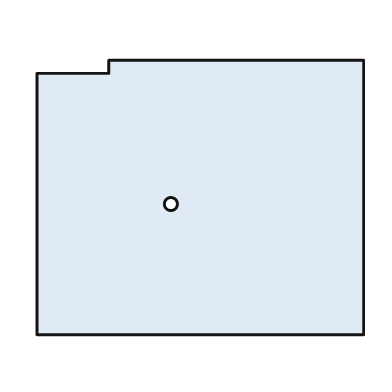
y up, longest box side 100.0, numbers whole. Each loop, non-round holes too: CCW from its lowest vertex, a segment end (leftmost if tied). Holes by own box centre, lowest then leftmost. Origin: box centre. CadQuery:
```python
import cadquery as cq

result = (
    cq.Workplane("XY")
    .moveTo(-50.0, -42.0)
    .lineTo(50.0, -42.0)
    .lineTo(50.0, 42.0)
    .lineTo(-28.0, 42.0)
    .lineTo(-28.0, 38.0)
    .lineTo(-50.0, 38.0)
    .close()
    .moveTo(-9.0, -2.0)
    .circle(2.0)
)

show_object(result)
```